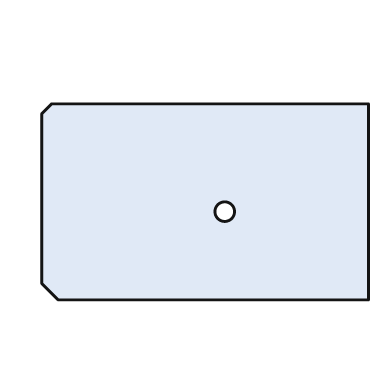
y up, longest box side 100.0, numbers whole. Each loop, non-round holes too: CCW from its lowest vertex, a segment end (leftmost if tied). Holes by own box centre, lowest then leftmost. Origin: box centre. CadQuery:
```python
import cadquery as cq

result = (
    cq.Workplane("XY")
    .moveTo(-45.0, -30.0)
    .lineTo(50.0, -30.0)
    .lineTo(50.0, 30.0)
    .lineTo(-47.0, 30.0)
    .lineTo(-50.0, 27.0)
    .lineTo(-50.0, -25.0)
    .close()
    .moveTo(6.0, -3.0)
    .circle(3.0)
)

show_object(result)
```